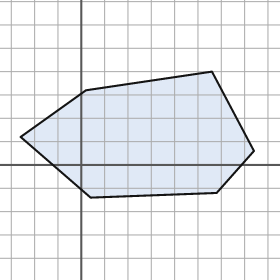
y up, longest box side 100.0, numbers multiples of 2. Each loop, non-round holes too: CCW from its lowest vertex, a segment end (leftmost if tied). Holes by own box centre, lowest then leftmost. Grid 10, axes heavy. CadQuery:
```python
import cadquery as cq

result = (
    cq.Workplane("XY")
    .moveTo(4.0, -14.0)
    .lineTo(58.0, -12.0)
    .lineTo(74.0, 6.0)
    .lineTo(56.0, 40.0)
    .lineTo(2.0, 32.0)
    .lineTo(-26.0, 12.0)
    .close()
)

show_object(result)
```